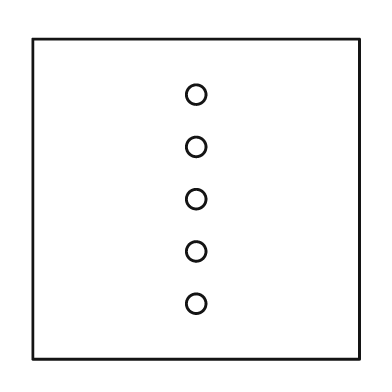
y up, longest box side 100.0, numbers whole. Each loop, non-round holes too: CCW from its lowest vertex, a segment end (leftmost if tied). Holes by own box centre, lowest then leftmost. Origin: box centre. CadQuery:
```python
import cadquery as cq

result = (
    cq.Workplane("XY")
    .moveTo(-50.0, -49.0)
    .lineTo(50.0, -49.0)
    .lineTo(50.0, 49.0)
    .lineTo(-50.0, 49.0)
    .close()
    .moveTo(0.0, -32.0)
    .circle(3.0)
    .moveTo(0.0, -16.0)
    .circle(3.0)
    .moveTo(0.0, 0.0)
    .circle(3.0)
    .moveTo(0.0, 16.0)
    .circle(3.0)
    .moveTo(0.0, 32.0)
    .circle(3.0)
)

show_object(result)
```